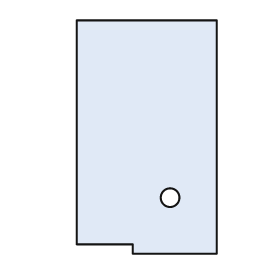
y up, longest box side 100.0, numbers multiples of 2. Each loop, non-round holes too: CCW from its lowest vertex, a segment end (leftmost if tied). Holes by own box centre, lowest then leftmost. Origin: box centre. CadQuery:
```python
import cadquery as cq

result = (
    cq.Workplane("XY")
    .moveTo(-6.0, -50.0)
    .lineTo(30.0, -50.0)
    .lineTo(30.0, 50.0)
    .lineTo(-30.0, 50.0)
    .lineTo(-30.0, -46.0)
    .lineTo(-6.0, -46.0)
    .close()
    .moveTo(10.0, -26.0)
    .circle(4.0)
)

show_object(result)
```